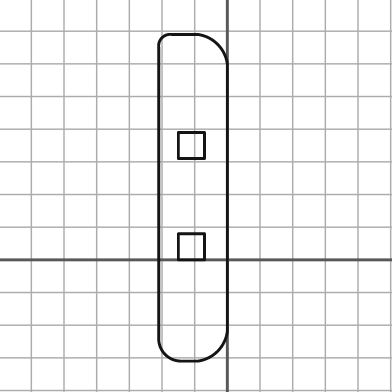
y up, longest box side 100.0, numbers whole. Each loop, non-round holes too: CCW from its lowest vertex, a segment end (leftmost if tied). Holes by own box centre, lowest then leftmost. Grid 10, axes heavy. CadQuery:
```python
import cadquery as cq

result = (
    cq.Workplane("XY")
    .moveTo(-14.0, -31.0)
    .lineTo(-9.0, -31.0)
    .threePointArc((-3.0, -28.0), (0.0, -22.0))
    .lineTo(0.0, 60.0)
    .threePointArc((-3.0, 66.0), (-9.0, 69.0))
    .lineTo(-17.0, 69.0)
    .threePointArc((-20.0, 68.0), (-21.0, 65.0))
    .lineTo(-21.0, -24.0)
    .threePointArc((-19.0, -29.0), (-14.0, -31.0))
    .close()
    .moveTo(-15.0, 0.0)
    .lineTo(-7.0, 0.0)
    .lineTo(-7.0, 8.0)
    .lineTo(-15.0, 8.0)
    .close()
    .moveTo(-15.0, 31.0)
    .lineTo(-7.0, 31.0)
    .lineTo(-7.0, 39.0)
    .lineTo(-15.0, 39.0)
    .close()
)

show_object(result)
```